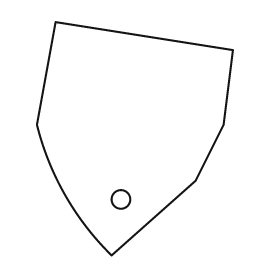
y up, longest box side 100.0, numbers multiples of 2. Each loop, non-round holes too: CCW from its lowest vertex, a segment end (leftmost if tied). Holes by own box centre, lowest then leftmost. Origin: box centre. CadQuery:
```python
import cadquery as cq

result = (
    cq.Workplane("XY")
    .moveTo(-10.0, -50.0)
    .lineTo(26.0, -18.0)
    .lineTo(38.0, 6.0)
    .lineTo(42.0, 38.0)
    .lineTo(-34.0, 50.0)
    .lineTo(-42.0, 6.0)
    .threePointArc((-30.0, -24.0), (-10.0, -50.0))
    .close()
    .moveTo(-6.0, -26.0)
    .circle(4.0)
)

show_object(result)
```